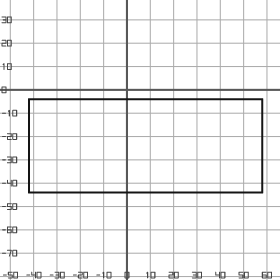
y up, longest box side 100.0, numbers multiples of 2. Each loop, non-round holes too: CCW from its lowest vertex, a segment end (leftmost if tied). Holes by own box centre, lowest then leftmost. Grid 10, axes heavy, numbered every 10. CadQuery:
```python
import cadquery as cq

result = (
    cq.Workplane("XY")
    .moveTo(-42.0, -44.0)
    .lineTo(58.0, -44.0)
    .lineTo(58.0, -4.0)
    .lineTo(-42.0, -4.0)
    .close()
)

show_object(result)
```